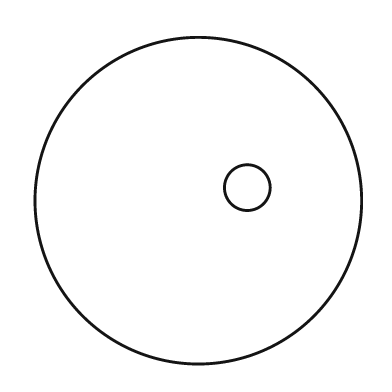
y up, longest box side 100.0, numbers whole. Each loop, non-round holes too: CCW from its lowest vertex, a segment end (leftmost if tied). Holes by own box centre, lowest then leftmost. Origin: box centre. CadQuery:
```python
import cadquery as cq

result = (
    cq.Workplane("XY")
    .moveTo(0.0, 0.0)
    .circle(50.0)
    .moveTo(15.0, 4.0)
    .circle(7.0)
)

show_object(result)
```